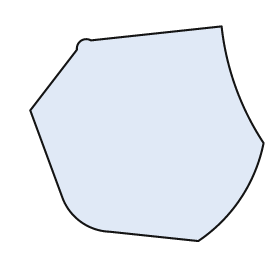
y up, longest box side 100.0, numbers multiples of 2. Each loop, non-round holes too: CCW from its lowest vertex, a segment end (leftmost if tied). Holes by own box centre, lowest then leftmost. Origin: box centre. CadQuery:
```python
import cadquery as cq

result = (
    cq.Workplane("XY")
    .moveTo(22.0, -46.0)
    .threePointArc((40.0, -28.0), (50.0, -4.0))
    .threePointArc((38.0, 20.0), (32.0, 46.0))
    .lineTo(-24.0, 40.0)
    .threePointArc((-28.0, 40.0), (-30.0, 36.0))
    .lineTo(-50.0, 10.0)
    .lineTo(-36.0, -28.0)
    .threePointArc((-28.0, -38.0), (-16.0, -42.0))
    .close()
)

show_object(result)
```